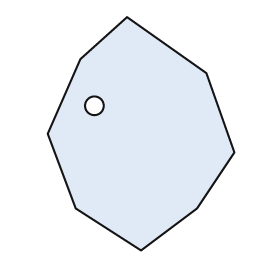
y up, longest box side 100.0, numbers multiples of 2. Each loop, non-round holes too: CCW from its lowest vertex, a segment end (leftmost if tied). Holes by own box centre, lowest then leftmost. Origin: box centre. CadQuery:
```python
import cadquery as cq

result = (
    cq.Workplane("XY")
    .moveTo(0.0, -50.0)
    .lineTo(24.0, -32.0)
    .lineTo(40.0, -8.0)
    .lineTo(28.0, 26.0)
    .lineTo(-6.0, 50.0)
    .lineTo(-26.0, 32.0)
    .lineTo(-40.0, 0.0)
    .lineTo(-28.0, -32.0)
    .close()
    .moveTo(-20.0, 12.0)
    .circle(4.0)
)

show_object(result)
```